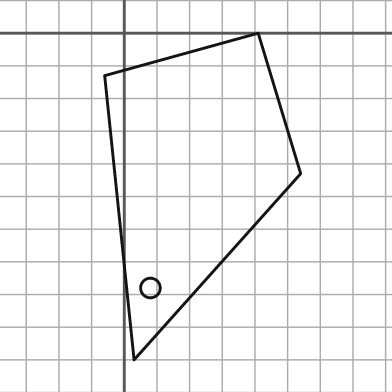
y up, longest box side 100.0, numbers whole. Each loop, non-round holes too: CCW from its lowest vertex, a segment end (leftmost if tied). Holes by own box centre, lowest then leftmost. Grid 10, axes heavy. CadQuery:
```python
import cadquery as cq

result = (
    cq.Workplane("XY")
    .moveTo(3.0, -100.0)
    .lineTo(54.0, -43.0)
    .lineTo(41.0, 0.0)
    .lineTo(-6.0, -13.0)
    .close()
    .moveTo(8.0, -78.0)
    .circle(3.0)
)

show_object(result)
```